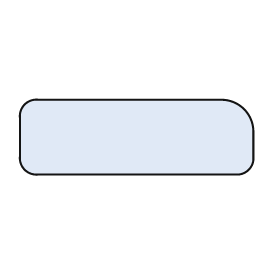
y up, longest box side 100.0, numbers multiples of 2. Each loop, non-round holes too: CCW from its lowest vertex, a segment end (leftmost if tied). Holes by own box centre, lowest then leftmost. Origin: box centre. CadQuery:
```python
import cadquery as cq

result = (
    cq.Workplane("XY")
    .moveTo(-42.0, -16.0)
    .lineTo(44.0, -16.0)
    .threePointArc((48.0, -14.0), (50.0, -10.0))
    .lineTo(50.0, 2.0)
    .threePointArc((46.0, 12.0), (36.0, 16.0))
    .lineTo(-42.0, 16.0)
    .threePointArc((-48.0, 14.0), (-50.0, 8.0))
    .lineTo(-50.0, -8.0)
    .threePointArc((-48.0, -14.0), (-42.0, -16.0))
    .close()
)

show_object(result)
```